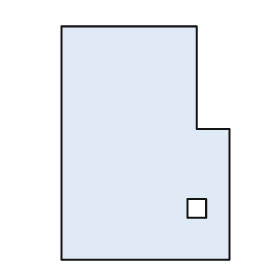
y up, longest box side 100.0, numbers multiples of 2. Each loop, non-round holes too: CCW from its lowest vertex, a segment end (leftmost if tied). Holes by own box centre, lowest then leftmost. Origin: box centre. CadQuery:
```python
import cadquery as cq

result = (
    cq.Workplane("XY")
    .moveTo(-36.0, -50.0)
    .lineTo(36.0, -50.0)
    .lineTo(36.0, 6.0)
    .lineTo(22.0, 6.0)
    .lineTo(22.0, 50.0)
    .lineTo(-36.0, 50.0)
    .close()
    .moveTo(18.0, -32.0)
    .lineTo(26.0, -32.0)
    .lineTo(26.0, -24.0)
    .lineTo(18.0, -24.0)
    .close()
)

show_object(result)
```